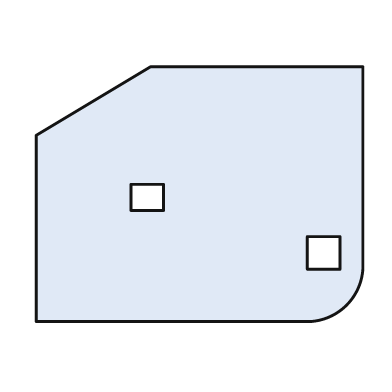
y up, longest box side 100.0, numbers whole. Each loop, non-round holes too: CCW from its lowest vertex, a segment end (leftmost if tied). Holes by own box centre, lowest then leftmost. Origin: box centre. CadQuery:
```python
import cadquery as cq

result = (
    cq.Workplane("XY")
    .moveTo(-50.0, -39.0)
    .lineTo(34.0, -39.0)
    .threePointArc((45.0, -34.0), (50.0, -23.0))
    .lineTo(50.0, 39.0)
    .lineTo(-15.0, 39.0)
    .lineTo(-50.0, 18.0)
    .close()
    .moveTo(33.0, -23.0)
    .lineTo(43.0, -23.0)
    .lineTo(43.0, -13.0)
    .lineTo(33.0, -13.0)
    .close()
    .moveTo(-21.0, -5.0)
    .lineTo(-11.0, -5.0)
    .lineTo(-11.0, 3.0)
    .lineTo(-21.0, 3.0)
    .close()
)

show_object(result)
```